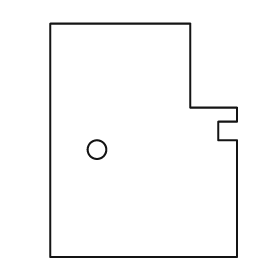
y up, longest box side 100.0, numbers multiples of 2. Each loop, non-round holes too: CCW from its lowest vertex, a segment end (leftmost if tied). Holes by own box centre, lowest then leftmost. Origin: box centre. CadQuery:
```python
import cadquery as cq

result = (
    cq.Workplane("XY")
    .moveTo(-40.0, -50.0)
    .lineTo(40.0, -50.0)
    .lineTo(40.0, 0.0)
    .lineTo(32.0, 0.0)
    .lineTo(32.0, 8.0)
    .lineTo(40.0, 8.0)
    .lineTo(40.0, 14.0)
    .lineTo(20.0, 14.0)
    .lineTo(20.0, 50.0)
    .lineTo(-40.0, 50.0)
    .close()
    .moveTo(-20.0, -4.0)
    .circle(4.0)
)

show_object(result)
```